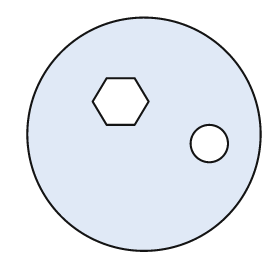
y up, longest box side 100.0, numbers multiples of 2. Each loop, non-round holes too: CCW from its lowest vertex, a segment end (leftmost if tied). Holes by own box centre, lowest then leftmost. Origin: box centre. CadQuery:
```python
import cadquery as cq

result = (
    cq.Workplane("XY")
    .moveTo(0.0, 0.0)
    .circle(50.0)
    .moveTo(28.0, -4.0)
    .circle(8.0)
    .moveTo(-16.0, 4.0)
    .lineTo(-4.0, 4.0)
    .lineTo(2.0, 14.0)
    .lineTo(-4.0, 24.0)
    .lineTo(-16.0, 24.0)
    .lineTo(-22.0, 14.0)
    .close()
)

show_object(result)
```